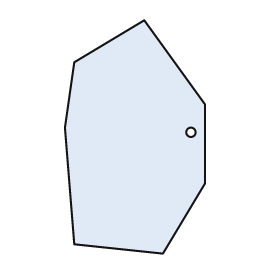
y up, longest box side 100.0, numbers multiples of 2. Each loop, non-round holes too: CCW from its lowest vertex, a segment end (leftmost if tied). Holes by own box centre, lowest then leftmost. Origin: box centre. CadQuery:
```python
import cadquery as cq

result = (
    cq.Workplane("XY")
    .moveTo(12.0, -50.0)
    .lineTo(30.0, -20.0)
    .lineTo(30.0, 14.0)
    .lineTo(4.0, 50.0)
    .lineTo(-26.0, 32.0)
    .lineTo(-30.0, 4.0)
    .lineTo(-26.0, -46.0)
    .close()
    .moveTo(24.0, 2.0)
    .circle(2.0)
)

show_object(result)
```